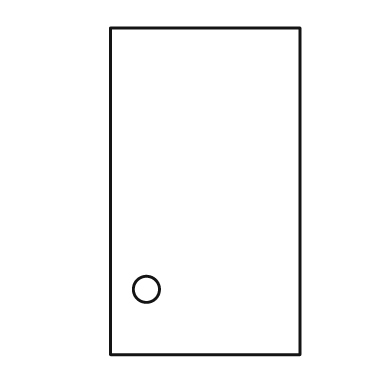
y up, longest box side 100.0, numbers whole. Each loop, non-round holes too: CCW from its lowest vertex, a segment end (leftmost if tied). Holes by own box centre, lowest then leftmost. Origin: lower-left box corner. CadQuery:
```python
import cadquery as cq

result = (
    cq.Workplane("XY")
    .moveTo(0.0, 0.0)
    .lineTo(58.0, 0.0)
    .lineTo(58.0, 100.0)
    .lineTo(0.0, 100.0)
    .close()
    .moveTo(11.0, 20.0)
    .circle(4.0)
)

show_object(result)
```